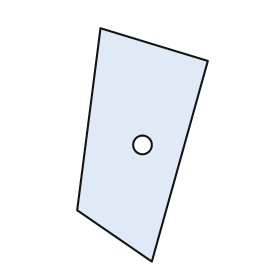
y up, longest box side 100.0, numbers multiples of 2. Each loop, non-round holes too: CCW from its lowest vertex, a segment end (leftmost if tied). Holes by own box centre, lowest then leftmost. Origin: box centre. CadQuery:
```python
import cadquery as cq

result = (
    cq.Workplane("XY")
    .moveTo(4.0, -50.0)
    .lineTo(28.0, 36.0)
    .lineTo(-18.0, 50.0)
    .lineTo(-28.0, -28.0)
    .close()
    .moveTo(0.0, 0.0)
    .circle(4.0)
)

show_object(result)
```